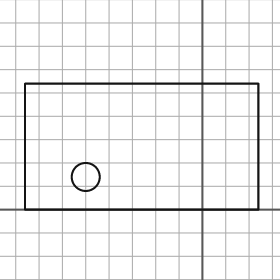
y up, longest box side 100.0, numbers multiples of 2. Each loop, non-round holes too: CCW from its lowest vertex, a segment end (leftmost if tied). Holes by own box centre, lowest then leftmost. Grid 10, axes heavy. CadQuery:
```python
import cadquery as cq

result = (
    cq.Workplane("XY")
    .moveTo(-76.0, 0.0)
    .lineTo(24.0, 0.0)
    .lineTo(24.0, 54.0)
    .lineTo(-76.0, 54.0)
    .close()
    .moveTo(-50.0, 14.0)
    .circle(6.0)
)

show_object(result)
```